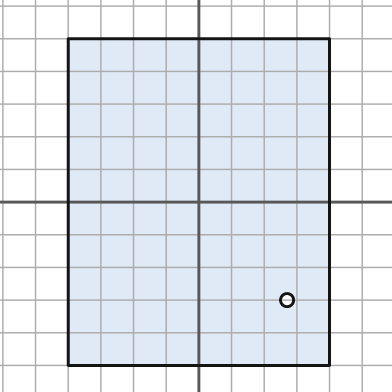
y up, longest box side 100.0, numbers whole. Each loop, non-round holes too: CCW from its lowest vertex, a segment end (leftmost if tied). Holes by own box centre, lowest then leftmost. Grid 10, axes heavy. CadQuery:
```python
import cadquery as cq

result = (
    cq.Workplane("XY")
    .moveTo(-40.0, -50.0)
    .lineTo(40.0, -50.0)
    .lineTo(40.0, 50.0)
    .lineTo(-40.0, 50.0)
    .close()
    .moveTo(27.0, -30.0)
    .circle(2.0)
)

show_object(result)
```